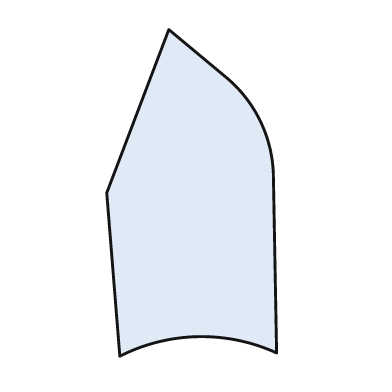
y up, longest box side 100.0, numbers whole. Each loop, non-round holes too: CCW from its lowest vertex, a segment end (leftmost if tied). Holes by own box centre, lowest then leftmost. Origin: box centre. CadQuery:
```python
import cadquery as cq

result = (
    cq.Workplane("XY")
    .moveTo(-22.0, -50.0)
    .threePointArc((2.0, -44.0), (26.0, -49.0))
    .lineTo(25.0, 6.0)
    .threePointArc((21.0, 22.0), (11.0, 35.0))
    .lineTo(-7.0, 50.0)
    .lineTo(-26.0, 0.0)
    .close()
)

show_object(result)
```